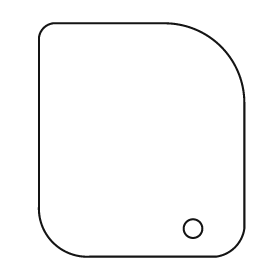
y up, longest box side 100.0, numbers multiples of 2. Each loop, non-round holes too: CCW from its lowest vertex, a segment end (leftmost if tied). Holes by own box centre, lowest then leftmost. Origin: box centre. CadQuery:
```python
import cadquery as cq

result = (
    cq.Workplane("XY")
    .moveTo(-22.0, -50.0)
    .lineTo(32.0, -50.0)
    .threePointArc((40.0, -46.0), (44.0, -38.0))
    .lineTo(44.0, 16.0)
    .threePointArc((34.0, 40.0), (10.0, 50.0))
    .lineTo(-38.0, 50.0)
    .threePointArc((-42.0, 48.0), (-44.0, 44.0))
    .lineTo(-44.0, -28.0)
    .threePointArc((-38.0, -44.0), (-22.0, -50.0))
    .close()
    .moveTo(22.0, -38.0)
    .circle(4.0)
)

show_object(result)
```